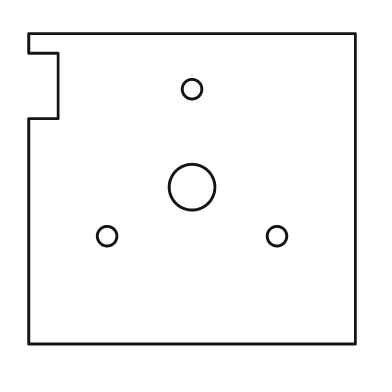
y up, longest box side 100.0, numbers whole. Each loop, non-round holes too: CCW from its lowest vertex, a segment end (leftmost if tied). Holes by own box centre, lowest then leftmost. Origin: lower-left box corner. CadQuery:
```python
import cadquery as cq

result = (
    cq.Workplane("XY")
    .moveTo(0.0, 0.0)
    .lineTo(100.0, 0.0)
    .lineTo(100.0, 95.0)
    .lineTo(0.0, 95.0)
    .lineTo(0.0, 89.0)
    .lineTo(9.0, 89.0)
    .lineTo(9.0, 69.0)
    .lineTo(0.0, 69.0)
    .close()
    .moveTo(24.0, 33.0)
    .circle(3.0)
    .moveTo(76.0, 33.0)
    .circle(3.0)
    .moveTo(50.0, 48.0)
    .circle(7.0)
    .moveTo(50.0, 78.0)
    .circle(3.0)
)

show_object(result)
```